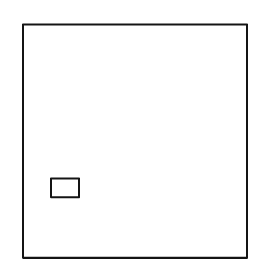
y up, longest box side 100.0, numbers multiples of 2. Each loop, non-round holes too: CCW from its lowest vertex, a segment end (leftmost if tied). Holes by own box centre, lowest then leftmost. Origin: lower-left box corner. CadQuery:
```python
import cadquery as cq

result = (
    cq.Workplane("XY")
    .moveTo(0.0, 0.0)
    .lineTo(96.0, 0.0)
    .lineTo(96.0, 100.0)
    .lineTo(0.0, 100.0)
    .close()
    .moveTo(12.0, 26.0)
    .lineTo(24.0, 26.0)
    .lineTo(24.0, 34.0)
    .lineTo(12.0, 34.0)
    .close()
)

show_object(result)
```